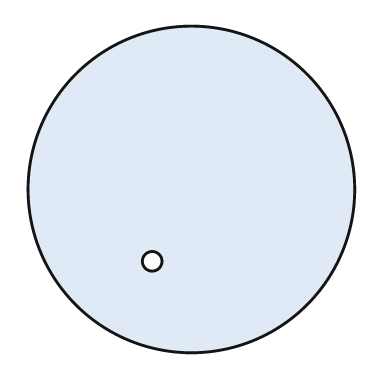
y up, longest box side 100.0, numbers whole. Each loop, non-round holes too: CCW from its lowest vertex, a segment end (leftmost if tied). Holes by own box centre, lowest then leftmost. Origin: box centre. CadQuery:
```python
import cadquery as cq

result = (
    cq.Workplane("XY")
    .moveTo(0.0, 0.0)
    .circle(50.0)
    .moveTo(-12.0, -22.0)
    .circle(3.0)
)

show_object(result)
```